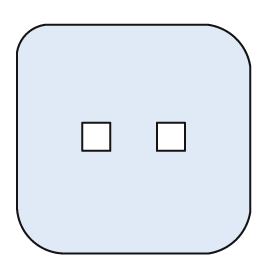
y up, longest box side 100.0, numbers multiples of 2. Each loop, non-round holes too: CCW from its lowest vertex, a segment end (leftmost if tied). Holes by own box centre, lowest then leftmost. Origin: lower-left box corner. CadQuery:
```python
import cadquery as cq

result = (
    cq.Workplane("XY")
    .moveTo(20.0, 0.0)
    .lineTo(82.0, 0.0)
    .threePointArc((94.0, 6.0), (100.0, 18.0))
    .lineTo(100.0, 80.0)
    .threePointArc((94.0, 92.0), (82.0, 98.0))
    .lineTo(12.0, 98.0)
    .threePointArc((4.0, 94.0), (0.0, 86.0))
    .lineTo(0.0, 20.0)
    .threePointArc((6.0, 6.0), (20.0, 0.0))
    .close()
    .moveTo(28.0, 44.0)
    .lineTo(40.0, 44.0)
    .lineTo(40.0, 56.0)
    .lineTo(28.0, 56.0)
    .close()
    .moveTo(60.0, 44.0)
    .lineTo(72.0, 44.0)
    .lineTo(72.0, 56.0)
    .lineTo(60.0, 56.0)
    .close()
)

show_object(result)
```